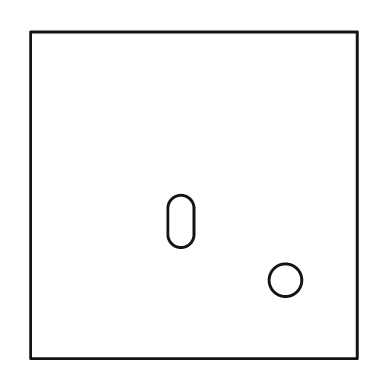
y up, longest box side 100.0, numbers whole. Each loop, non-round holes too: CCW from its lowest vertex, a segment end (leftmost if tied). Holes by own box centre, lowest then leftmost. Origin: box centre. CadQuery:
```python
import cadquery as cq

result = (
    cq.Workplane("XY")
    .moveTo(-50.0, -50.0)
    .lineTo(50.0, -50.0)
    .lineTo(50.0, 50.0)
    .lineTo(-50.0, 50.0)
    .close()
    .moveTo(28.0, -26.0)
    .circle(5.0)
    .moveTo(-8.0, -12.0)
    .threePointArc((-4.0, -16.0), (0.0, -12.0))
    .lineTo(0.0, -4.0)
    .threePointArc((-4.0, 0.0), (-8.0, -4.0))
    .close()
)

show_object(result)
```